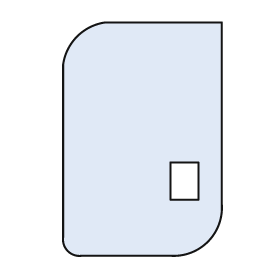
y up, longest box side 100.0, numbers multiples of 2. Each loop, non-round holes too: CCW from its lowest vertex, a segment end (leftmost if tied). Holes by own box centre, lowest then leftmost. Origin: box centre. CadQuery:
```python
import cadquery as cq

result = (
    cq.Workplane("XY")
    .moveTo(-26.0, -50.0)
    .lineTo(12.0, -50.0)
    .threePointArc((28.0, -44.0), (34.0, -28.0))
    .lineTo(34.0, 50.0)
    .lineTo(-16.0, 50.0)
    .threePointArc((-28.0, 44.0), (-34.0, 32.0))
    .lineTo(-34.0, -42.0)
    .threePointArc((-32.0, -48.0), (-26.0, -50.0))
    .close()
    .moveTo(12.0, -26.0)
    .lineTo(24.0, -26.0)
    .lineTo(24.0, -10.0)
    .lineTo(12.0, -10.0)
    .close()
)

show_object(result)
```